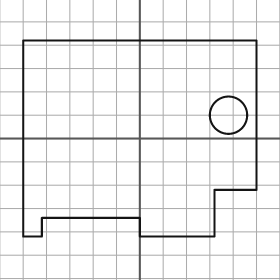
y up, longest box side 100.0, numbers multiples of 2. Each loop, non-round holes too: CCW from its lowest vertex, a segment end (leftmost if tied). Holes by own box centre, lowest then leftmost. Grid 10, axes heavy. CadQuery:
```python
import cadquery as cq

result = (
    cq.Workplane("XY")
    .moveTo(-50.0, -42.0)
    .lineTo(-42.0, -42.0)
    .lineTo(-42.0, -34.0)
    .lineTo(0.0, -34.0)
    .lineTo(0.0, -42.0)
    .lineTo(32.0, -42.0)
    .lineTo(32.0, -22.0)
    .lineTo(50.0, -22.0)
    .lineTo(50.0, 42.0)
    .lineTo(-50.0, 42.0)
    .close()
    .moveTo(38.0, 10.0)
    .circle(8.0)
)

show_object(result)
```